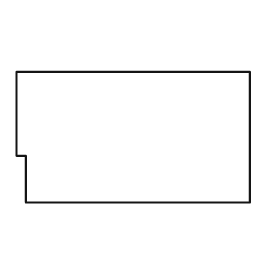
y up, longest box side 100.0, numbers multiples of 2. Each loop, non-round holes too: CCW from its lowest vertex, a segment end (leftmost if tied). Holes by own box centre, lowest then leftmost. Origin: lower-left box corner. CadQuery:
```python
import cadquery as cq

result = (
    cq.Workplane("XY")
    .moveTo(4.0, 0.0)
    .lineTo(100.0, 0.0)
    .lineTo(100.0, 56.0)
    .lineTo(0.0, 56.0)
    .lineTo(0.0, 20.0)
    .lineTo(4.0, 20.0)
    .close()
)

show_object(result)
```